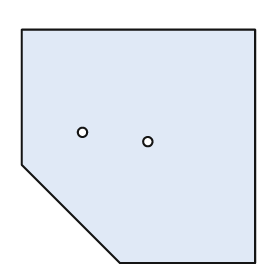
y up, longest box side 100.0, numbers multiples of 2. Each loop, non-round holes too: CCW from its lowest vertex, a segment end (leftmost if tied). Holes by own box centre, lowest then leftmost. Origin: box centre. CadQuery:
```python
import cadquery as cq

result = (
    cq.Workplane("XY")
    .moveTo(-8.0, -50.0)
    .lineTo(50.0, -50.0)
    .lineTo(50.0, 50.0)
    .lineTo(-50.0, 50.0)
    .lineTo(-50.0, -8.0)
    .close()
    .moveTo(4.0, 2.0)
    .circle(2.0)
    .moveTo(-24.0, 6.0)
    .circle(2.0)
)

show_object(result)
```